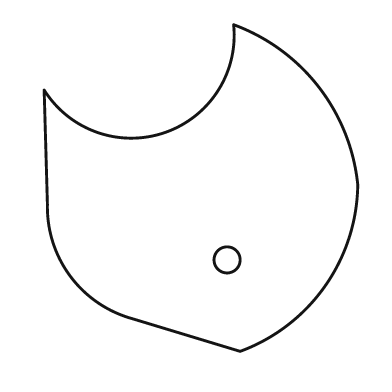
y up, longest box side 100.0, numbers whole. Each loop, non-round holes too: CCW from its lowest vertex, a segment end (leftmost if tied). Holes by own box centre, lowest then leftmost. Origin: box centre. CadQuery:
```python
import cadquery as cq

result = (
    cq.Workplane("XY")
    .moveTo(12.0, -50.0)
    .threePointArc((38.0, -30.0), (48.0, 1.0))
    .threePointArc((36.0, 31.0), (10.0, 50.0))
    .threePointArc((-11.0, 17.0), (-48.0, 30.0))
    .lineTo(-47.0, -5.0)
    .threePointArc((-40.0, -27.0), (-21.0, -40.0))
    .close()
    .moveTo(8.0, -22.0)
    .circle(4.0)
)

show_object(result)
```